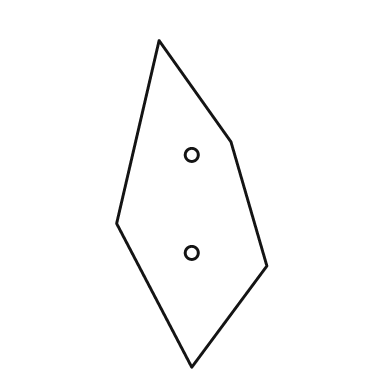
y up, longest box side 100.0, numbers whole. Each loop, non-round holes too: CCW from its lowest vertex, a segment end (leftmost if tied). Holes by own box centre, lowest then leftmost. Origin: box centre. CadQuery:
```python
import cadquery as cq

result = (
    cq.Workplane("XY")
    .moveTo(0.0, -50.0)
    .lineTo(23.0, -19.0)
    .lineTo(12.0, 19.0)
    .lineTo(-10.0, 50.0)
    .lineTo(-23.0, -6.0)
    .close()
    .moveTo(0.0, -15.0)
    .circle(2.0)
    .moveTo(0.0, 15.0)
    .circle(2.0)
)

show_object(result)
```